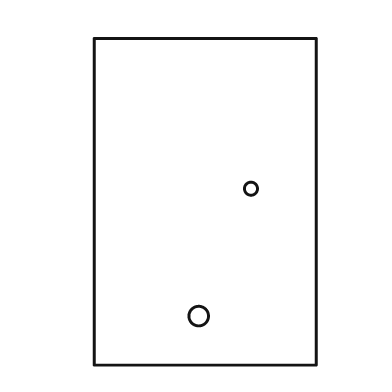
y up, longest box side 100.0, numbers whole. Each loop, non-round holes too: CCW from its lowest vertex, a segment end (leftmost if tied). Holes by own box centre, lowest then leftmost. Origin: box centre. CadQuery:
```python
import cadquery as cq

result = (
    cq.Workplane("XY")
    .moveTo(-34.0, -50.0)
    .lineTo(34.0, -50.0)
    .lineTo(34.0, 50.0)
    .lineTo(-34.0, 50.0)
    .close()
    .moveTo(-2.0, -35.0)
    .circle(3.0)
    .moveTo(14.0, 4.0)
    .circle(2.0)
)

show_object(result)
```